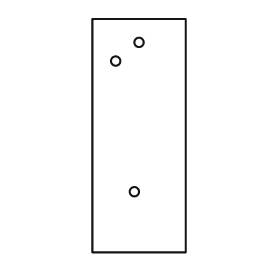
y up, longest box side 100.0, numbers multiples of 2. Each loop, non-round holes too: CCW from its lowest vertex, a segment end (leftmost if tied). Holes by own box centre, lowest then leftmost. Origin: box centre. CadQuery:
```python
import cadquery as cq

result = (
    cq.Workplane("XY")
    .moveTo(-20.0, -50.0)
    .lineTo(20.0, -50.0)
    .lineTo(20.0, 50.0)
    .lineTo(-20.0, 50.0)
    .close()
    .moveTo(-2.0, -24.0)
    .circle(2.0)
    .moveTo(-10.0, 32.0)
    .circle(2.0)
    .moveTo(0.0, 40.0)
    .circle(2.0)
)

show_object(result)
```